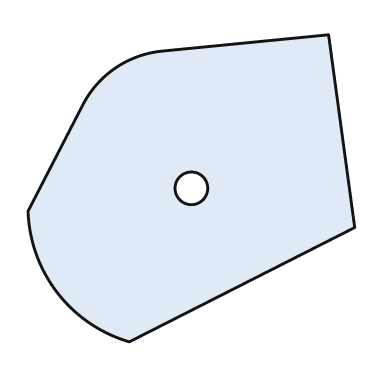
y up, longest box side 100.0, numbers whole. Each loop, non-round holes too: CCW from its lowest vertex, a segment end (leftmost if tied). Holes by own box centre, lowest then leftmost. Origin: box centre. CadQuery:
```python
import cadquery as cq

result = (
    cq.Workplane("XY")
    .moveTo(-19.0, -47.0)
    .lineTo(50.0, -12.0)
    .lineTo(42.0, 47.0)
    .lineTo(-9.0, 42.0)
    .threePointArc((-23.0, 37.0), (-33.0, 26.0))
    .lineTo(-50.0, -7.0)
    .threePointArc((-41.0, -32.0), (-19.0, -47.0))
    .close()
    .moveTo(0.0, 0.0)
    .circle(5.0)
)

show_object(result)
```